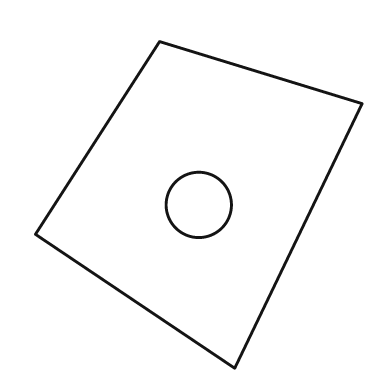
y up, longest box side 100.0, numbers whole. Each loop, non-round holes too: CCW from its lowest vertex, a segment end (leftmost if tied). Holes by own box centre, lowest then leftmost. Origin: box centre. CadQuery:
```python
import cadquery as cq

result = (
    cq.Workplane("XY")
    .moveTo(11.0, -50.0)
    .lineTo(50.0, 31.0)
    .lineTo(-12.0, 50.0)
    .lineTo(-50.0, -9.0)
    .close()
    .moveTo(0.0, 0.0)
    .circle(10.0)
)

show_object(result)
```